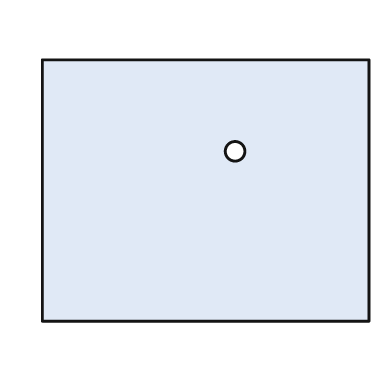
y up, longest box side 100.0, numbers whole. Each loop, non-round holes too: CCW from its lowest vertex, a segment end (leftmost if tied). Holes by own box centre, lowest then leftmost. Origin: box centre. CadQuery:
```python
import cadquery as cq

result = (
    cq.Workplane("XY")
    .moveTo(-50.0, -40.0)
    .lineTo(50.0, -40.0)
    .lineTo(50.0, 40.0)
    .lineTo(-50.0, 40.0)
    .close()
    .moveTo(9.0, 12.0)
    .circle(3.0)
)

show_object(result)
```